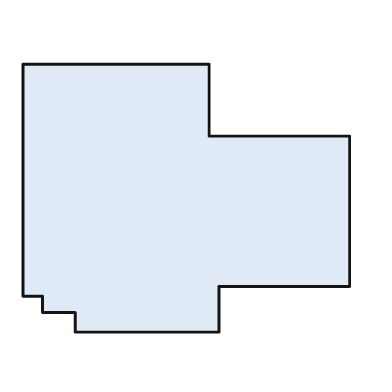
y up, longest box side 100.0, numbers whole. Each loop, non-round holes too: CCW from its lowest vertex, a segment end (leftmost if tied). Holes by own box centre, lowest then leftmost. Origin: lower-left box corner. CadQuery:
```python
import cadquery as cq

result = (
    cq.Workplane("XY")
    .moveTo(16.0, 0.0)
    .lineTo(60.0, 0.0)
    .lineTo(60.0, 14.0)
    .lineTo(100.0, 14.0)
    .lineTo(100.0, 60.0)
    .lineTo(57.0, 60.0)
    .lineTo(57.0, 82.0)
    .lineTo(0.0, 82.0)
    .lineTo(0.0, 11.0)
    .lineTo(6.0, 11.0)
    .lineTo(6.0, 6.0)
    .lineTo(16.0, 6.0)
    .close()
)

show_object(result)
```